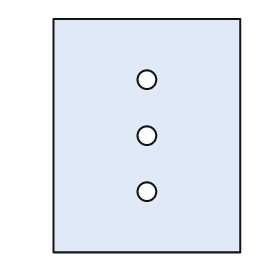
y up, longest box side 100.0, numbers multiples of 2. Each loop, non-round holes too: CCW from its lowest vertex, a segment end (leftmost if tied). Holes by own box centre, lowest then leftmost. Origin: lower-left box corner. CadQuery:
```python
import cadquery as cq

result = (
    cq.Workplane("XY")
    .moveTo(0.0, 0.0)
    .lineTo(80.0, 0.0)
    .lineTo(80.0, 100.0)
    .lineTo(0.0, 100.0)
    .close()
    .moveTo(40.0, 26.0)
    .circle(4.0)
    .moveTo(40.0, 50.0)
    .circle(4.0)
    .moveTo(40.0, 74.0)
    .circle(4.0)
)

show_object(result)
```